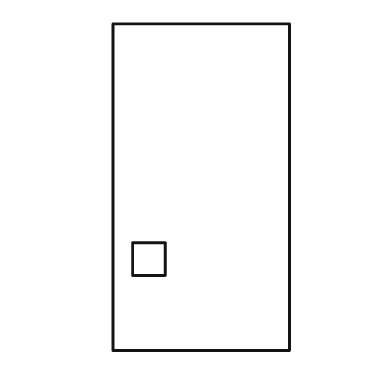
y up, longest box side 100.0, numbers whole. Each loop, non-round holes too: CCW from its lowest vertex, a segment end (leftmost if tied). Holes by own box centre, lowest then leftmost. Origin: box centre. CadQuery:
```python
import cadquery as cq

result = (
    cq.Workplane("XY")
    .moveTo(-27.0, -50.0)
    .lineTo(27.0, -50.0)
    .lineTo(27.0, 50.0)
    .lineTo(-27.0, 50.0)
    .close()
    .moveTo(-21.0, -27.0)
    .lineTo(-11.0, -27.0)
    .lineTo(-11.0, -17.0)
    .lineTo(-21.0, -17.0)
    .close()
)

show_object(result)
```